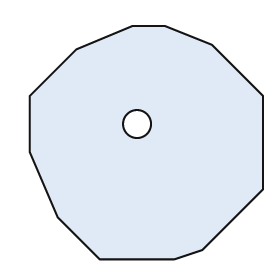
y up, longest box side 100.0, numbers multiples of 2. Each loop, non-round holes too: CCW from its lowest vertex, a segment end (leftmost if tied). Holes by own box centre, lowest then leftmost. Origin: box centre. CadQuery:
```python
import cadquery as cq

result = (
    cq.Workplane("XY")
    .moveTo(-20.0, -50.0)
    .lineTo(12.0, -50.0)
    .lineTo(24.0, -46.0)
    .lineTo(50.0, -20.0)
    .lineTo(50.0, 20.0)
    .lineTo(28.0, 42.0)
    .lineTo(8.0, 50.0)
    .lineTo(-6.0, 50.0)
    .lineTo(-30.0, 40.0)
    .lineTo(-50.0, 20.0)
    .lineTo(-50.0, -4.0)
    .lineTo(-38.0, -32.0)
    .close()
    .moveTo(-4.0, 8.0)
    .circle(6.0)
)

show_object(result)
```